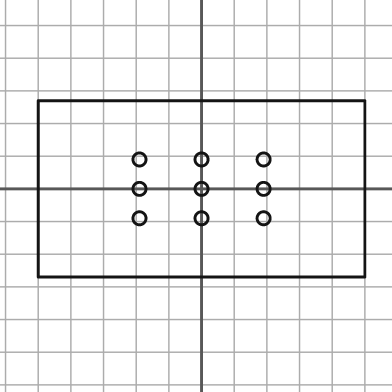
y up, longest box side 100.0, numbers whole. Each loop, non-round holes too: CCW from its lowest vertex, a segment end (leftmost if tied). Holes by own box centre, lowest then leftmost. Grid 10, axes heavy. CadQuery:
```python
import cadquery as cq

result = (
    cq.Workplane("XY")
    .moveTo(-50.0, -27.0)
    .lineTo(50.0, -27.0)
    .lineTo(50.0, 27.0)
    .lineTo(-50.0, 27.0)
    .close()
    .moveTo(-19.0, -9.0)
    .circle(2.0)
    .moveTo(0.0, -9.0)
    .circle(2.0)
    .moveTo(19.0, -9.0)
    .circle(2.0)
    .moveTo(-19.0, 0.0)
    .circle(2.0)
    .moveTo(0.0, 0.0)
    .circle(2.0)
    .moveTo(19.0, 0.0)
    .circle(2.0)
    .moveTo(-19.0, 9.0)
    .circle(2.0)
    .moveTo(0.0, 9.0)
    .circle(2.0)
    .moveTo(19.0, 9.0)
    .circle(2.0)
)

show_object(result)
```